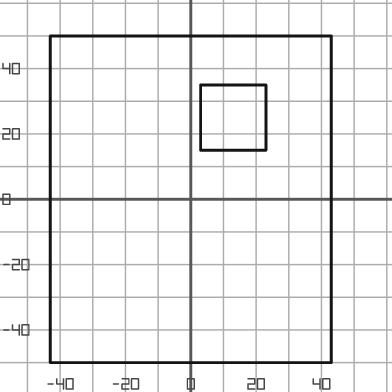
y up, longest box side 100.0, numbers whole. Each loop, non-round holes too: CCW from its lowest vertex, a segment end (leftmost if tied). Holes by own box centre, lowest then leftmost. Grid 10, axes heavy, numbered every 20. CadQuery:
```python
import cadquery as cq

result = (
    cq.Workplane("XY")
    .moveTo(-43.0, -50.0)
    .lineTo(43.0, -50.0)
    .lineTo(43.0, 50.0)
    .lineTo(-43.0, 50.0)
    .close()
    .moveTo(3.0, 15.0)
    .lineTo(23.0, 15.0)
    .lineTo(23.0, 35.0)
    .lineTo(3.0, 35.0)
    .close()
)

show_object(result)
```